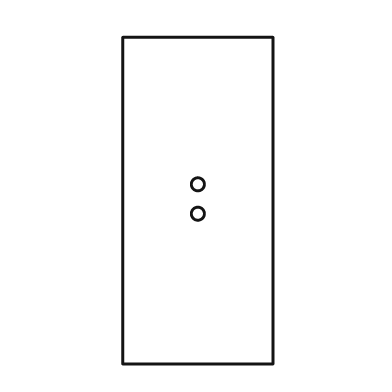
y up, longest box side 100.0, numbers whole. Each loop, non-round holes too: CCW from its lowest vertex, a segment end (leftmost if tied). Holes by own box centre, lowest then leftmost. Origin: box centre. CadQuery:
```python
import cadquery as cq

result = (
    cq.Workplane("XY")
    .moveTo(-23.0, -50.0)
    .lineTo(23.0, -50.0)
    .lineTo(23.0, 50.0)
    .lineTo(-23.0, 50.0)
    .close()
    .moveTo(0.0, -4.0)
    .circle(2.0)
    .moveTo(0.0, 5.0)
    .circle(2.0)
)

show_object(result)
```